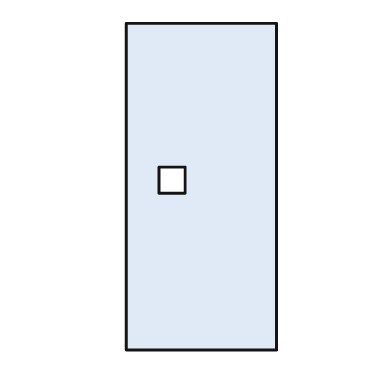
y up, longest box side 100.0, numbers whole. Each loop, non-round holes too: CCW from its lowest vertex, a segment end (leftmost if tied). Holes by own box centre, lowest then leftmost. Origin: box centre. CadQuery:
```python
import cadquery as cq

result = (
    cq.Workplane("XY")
    .moveTo(-23.0, -50.0)
    .lineTo(23.0, -50.0)
    .lineTo(23.0, 50.0)
    .lineTo(-23.0, 50.0)
    .close()
    .moveTo(-13.0, -2.0)
    .lineTo(-5.0, -2.0)
    .lineTo(-5.0, 6.0)
    .lineTo(-13.0, 6.0)
    .close()
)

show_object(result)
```